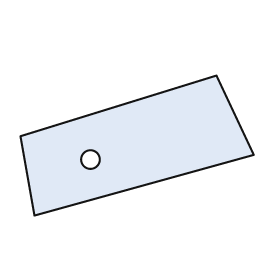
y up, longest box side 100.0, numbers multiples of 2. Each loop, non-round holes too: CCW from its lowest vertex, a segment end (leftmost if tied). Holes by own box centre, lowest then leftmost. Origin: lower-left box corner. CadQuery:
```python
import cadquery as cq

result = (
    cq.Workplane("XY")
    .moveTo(6.0, 0.0)
    .lineTo(100.0, 26.0)
    .lineTo(84.0, 60.0)
    .lineTo(0.0, 34.0)
    .close()
    .moveTo(30.0, 24.0)
    .circle(4.0)
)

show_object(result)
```